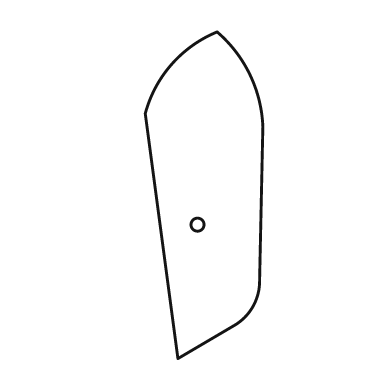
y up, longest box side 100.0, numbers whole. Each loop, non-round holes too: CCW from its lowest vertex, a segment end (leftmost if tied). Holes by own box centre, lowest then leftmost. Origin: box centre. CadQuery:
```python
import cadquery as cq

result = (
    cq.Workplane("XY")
    .moveTo(-8.0, -50.0)
    .lineTo(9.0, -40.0)
    .threePointArc((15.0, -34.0), (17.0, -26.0))
    .lineTo(18.0, 21.0)
    .threePointArc((14.0, 37.0), (4.0, 50.0))
    .threePointArc((-10.0, 40.0), (-18.0, 25.0))
    .close()
    .moveTo(-2.0, -9.0)
    .circle(2.0)
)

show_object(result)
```